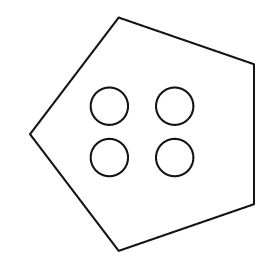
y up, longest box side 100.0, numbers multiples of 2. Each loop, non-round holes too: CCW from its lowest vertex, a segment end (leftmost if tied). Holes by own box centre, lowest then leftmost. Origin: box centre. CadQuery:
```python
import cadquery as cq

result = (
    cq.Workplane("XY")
    .moveTo(-10.0, -50.0)
    .lineTo(48.0, -30.0)
    .lineTo(48.0, 30.0)
    .lineTo(-10.0, 50.0)
    .lineTo(-48.0, 0.0)
    .close()
    .moveTo(-14.0, -10.0)
    .circle(8.0)
    .moveTo(14.0, -10.0)
    .circle(8.0)
    .moveTo(-14.0, 12.0)
    .circle(8.0)
    .moveTo(14.0, 12.0)
    .circle(8.0)
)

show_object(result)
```